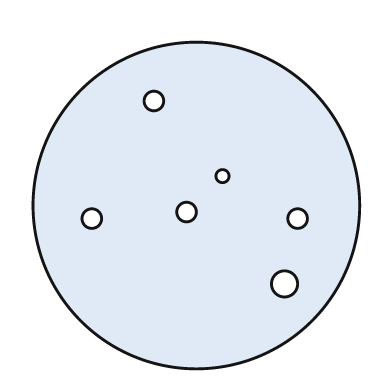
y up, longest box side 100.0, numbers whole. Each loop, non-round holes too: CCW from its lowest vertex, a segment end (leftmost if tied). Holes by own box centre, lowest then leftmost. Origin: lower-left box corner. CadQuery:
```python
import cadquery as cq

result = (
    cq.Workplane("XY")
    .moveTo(50.0, 50.0)
    .circle(50.0)
    .moveTo(77.0, 26.0)
    .circle(4.0)
    .moveTo(18.0, 46.0)
    .circle(3.0)
    .moveTo(81.0, 46.0)
    .circle(3.0)
    .moveTo(47.0, 48.0)
    .circle(3.0)
    .moveTo(58.0, 59.0)
    .circle(2.0)
    .moveTo(37.0, 82.0)
    .circle(3.0)
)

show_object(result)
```